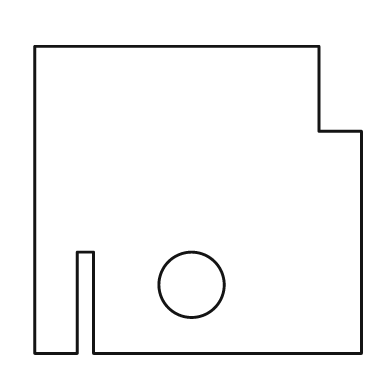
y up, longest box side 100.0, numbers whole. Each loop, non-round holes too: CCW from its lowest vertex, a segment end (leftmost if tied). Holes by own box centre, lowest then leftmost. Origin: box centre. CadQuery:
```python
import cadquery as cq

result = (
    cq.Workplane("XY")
    .moveTo(-50.0, -47.0)
    .lineTo(-37.0, -47.0)
    .lineTo(-37.0, -16.0)
    .lineTo(-32.0, -16.0)
    .lineTo(-32.0, -47.0)
    .lineTo(50.0, -47.0)
    .lineTo(50.0, 21.0)
    .lineTo(37.0, 21.0)
    .lineTo(37.0, 47.0)
    .lineTo(-50.0, 47.0)
    .close()
    .moveTo(-2.0, -26.0)
    .circle(10.0)
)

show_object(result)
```